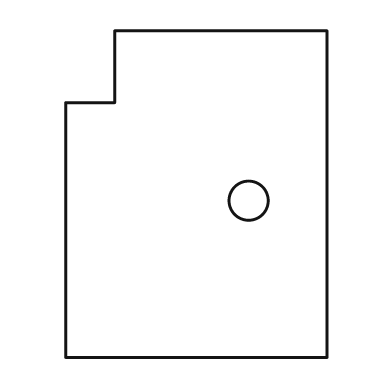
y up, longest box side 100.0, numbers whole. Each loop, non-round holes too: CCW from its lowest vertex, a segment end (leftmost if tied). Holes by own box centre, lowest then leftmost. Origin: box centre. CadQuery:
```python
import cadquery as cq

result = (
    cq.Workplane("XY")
    .moveTo(-40.0, -50.0)
    .lineTo(40.0, -50.0)
    .lineTo(40.0, 50.0)
    .lineTo(-25.0, 50.0)
    .lineTo(-25.0, 28.0)
    .lineTo(-40.0, 28.0)
    .close()
    .moveTo(16.0, -2.0)
    .circle(6.0)
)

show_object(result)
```